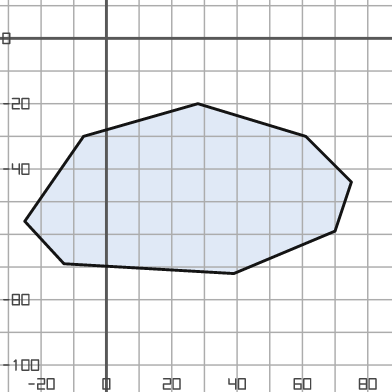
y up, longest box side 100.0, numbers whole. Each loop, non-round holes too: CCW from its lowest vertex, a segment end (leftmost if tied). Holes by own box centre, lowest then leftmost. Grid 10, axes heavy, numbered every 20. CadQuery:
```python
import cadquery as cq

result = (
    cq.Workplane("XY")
    .moveTo(39.0, -72.0)
    .lineTo(70.0, -59.0)
    .lineTo(75.0, -44.0)
    .lineTo(61.0, -30.0)
    .lineTo(28.0, -20.0)
    .lineTo(-7.0, -30.0)
    .lineTo(-25.0, -56.0)
    .lineTo(-13.0, -69.0)
    .close()
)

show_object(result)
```